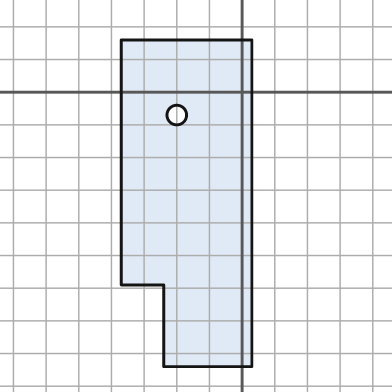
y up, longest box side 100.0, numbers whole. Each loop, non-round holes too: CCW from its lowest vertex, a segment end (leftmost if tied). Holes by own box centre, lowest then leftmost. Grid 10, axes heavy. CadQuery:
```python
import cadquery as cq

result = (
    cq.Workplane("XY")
    .moveTo(-24.0, -84.0)
    .lineTo(3.0, -84.0)
    .lineTo(3.0, 16.0)
    .lineTo(-37.0, 16.0)
    .lineTo(-37.0, -59.0)
    .lineTo(-24.0, -59.0)
    .close()
    .moveTo(-20.0, -7.0)
    .circle(3.0)
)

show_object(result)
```